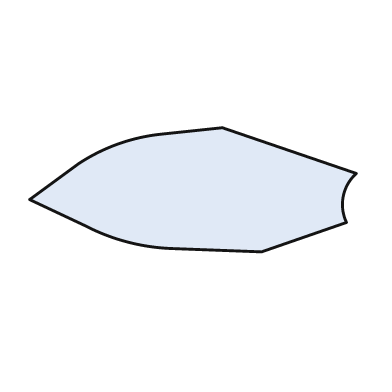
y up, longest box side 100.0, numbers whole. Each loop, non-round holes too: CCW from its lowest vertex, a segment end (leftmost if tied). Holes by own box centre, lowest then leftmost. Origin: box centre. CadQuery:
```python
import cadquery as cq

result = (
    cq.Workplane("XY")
    .moveTo(21.0, -19.0)
    .lineTo(47.0, -10.0)
    .threePointArc((46.0, -2.0), (50.0, 5.0))
    .lineTo(9.0, 19.0)
    .lineTo(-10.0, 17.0)
    .threePointArc((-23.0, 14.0), (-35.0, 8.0))
    .lineTo(-50.0, -3.0)
    .lineTo(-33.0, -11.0)
    .threePointArc((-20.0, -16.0), (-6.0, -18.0))
    .close()
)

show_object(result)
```